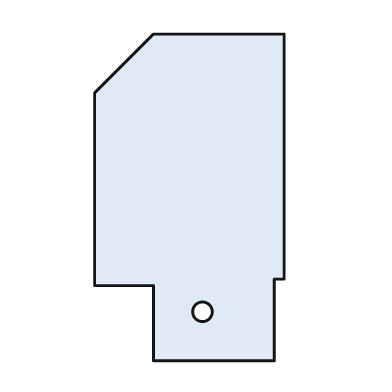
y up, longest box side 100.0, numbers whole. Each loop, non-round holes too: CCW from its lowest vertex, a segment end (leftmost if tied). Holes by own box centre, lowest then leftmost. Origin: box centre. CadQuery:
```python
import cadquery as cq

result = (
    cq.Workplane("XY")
    .moveTo(-11.0, -50.0)
    .lineTo(26.0, -50.0)
    .lineTo(26.0, -25.0)
    .lineTo(29.0, -25.0)
    .lineTo(29.0, 50.0)
    .lineTo(-11.0, 50.0)
    .lineTo(-29.0, 32.0)
    .lineTo(-29.0, -27.0)
    .lineTo(-11.0, -27.0)
    .close()
    .moveTo(4.0, -35.0)
    .circle(3.0)
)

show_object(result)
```